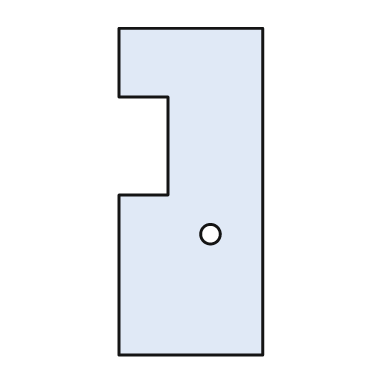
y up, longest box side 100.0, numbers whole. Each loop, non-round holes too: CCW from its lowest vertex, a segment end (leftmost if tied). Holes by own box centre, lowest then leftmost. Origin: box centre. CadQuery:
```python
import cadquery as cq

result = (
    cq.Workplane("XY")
    .moveTo(-22.0, -50.0)
    .lineTo(22.0, -50.0)
    .lineTo(22.0, 50.0)
    .lineTo(-22.0, 50.0)
    .lineTo(-22.0, 29.0)
    .lineTo(-7.0, 29.0)
    .lineTo(-7.0, -1.0)
    .lineTo(-22.0, -1.0)
    .close()
    .moveTo(6.0, -13.0)
    .circle(3.0)
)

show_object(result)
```